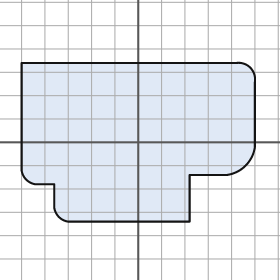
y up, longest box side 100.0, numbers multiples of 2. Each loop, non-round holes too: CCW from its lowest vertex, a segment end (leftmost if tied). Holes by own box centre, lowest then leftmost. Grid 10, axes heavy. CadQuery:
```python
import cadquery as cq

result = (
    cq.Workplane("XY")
    .moveTo(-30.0, -34.0)
    .lineTo(22.0, -34.0)
    .lineTo(22.0, -14.0)
    .lineTo(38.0, -14.0)
    .threePointArc((46.0, -10.0), (50.0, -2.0))
    .lineTo(50.0, 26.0)
    .threePointArc((48.0, 32.0), (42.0, 34.0))
    .lineTo(-50.0, 34.0)
    .lineTo(-50.0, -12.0)
    .threePointArc((-48.0, -16.0), (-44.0, -18.0))
    .lineTo(-36.0, -18.0)
    .lineTo(-36.0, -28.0)
    .threePointArc((-34.0, -32.0), (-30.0, -34.0))
    .close()
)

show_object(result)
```